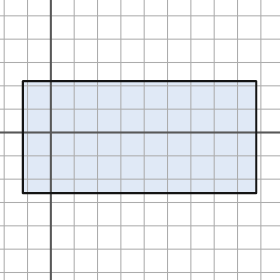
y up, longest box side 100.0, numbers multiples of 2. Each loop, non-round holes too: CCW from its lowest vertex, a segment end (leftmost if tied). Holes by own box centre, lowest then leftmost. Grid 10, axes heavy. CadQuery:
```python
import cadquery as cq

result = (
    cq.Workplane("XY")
    .moveTo(-12.0, -26.0)
    .lineTo(88.0, -26.0)
    .lineTo(88.0, 22.0)
    .lineTo(-12.0, 22.0)
    .close()
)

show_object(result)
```